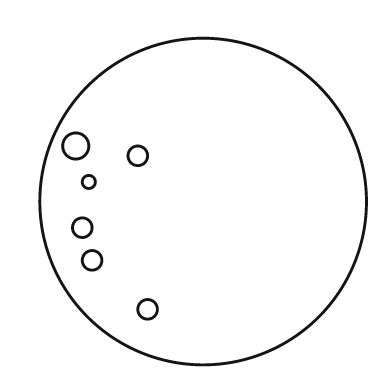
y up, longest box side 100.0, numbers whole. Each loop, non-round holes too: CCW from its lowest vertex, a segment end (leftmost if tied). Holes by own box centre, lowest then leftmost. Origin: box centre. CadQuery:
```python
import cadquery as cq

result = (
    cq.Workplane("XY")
    .moveTo(0.0, 0.0)
    .circle(50.0)
    .moveTo(-17.0, -33.0)
    .circle(3.0)
    .moveTo(-34.0, -18.0)
    .circle(3.0)
    .moveTo(-37.0, -8.0)
    .circle(3.0)
    .moveTo(-35.0, 6.0)
    .circle(2.0)
    .moveTo(-20.0, 14.0)
    .circle(3.0)
    .moveTo(-39.0, 17.0)
    .circle(4.0)
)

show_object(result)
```